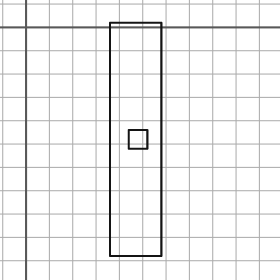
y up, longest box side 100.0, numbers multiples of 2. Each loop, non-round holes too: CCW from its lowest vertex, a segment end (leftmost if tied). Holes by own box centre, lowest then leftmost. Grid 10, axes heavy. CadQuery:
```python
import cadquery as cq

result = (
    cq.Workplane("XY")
    .moveTo(36.0, -98.0)
    .lineTo(58.0, -98.0)
    .lineTo(58.0, 2.0)
    .lineTo(36.0, 2.0)
    .close()
    .moveTo(44.0, -52.0)
    .lineTo(52.0, -52.0)
    .lineTo(52.0, -44.0)
    .lineTo(44.0, -44.0)
    .close()
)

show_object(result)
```